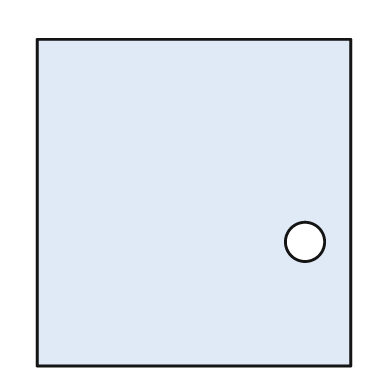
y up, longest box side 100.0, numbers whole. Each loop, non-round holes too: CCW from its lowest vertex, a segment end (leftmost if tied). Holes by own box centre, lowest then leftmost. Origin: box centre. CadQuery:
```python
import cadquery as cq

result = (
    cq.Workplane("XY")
    .moveTo(-48.0, -50.0)
    .lineTo(48.0, -50.0)
    .lineTo(48.0, 50.0)
    .lineTo(-48.0, 50.0)
    .close()
    .moveTo(34.0, -12.0)
    .circle(6.0)
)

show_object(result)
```